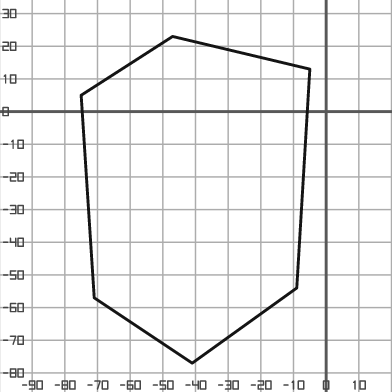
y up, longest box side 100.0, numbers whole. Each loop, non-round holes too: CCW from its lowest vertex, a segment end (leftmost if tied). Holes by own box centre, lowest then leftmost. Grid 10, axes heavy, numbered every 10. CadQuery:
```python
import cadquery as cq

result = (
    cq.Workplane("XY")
    .moveTo(-41.0, -77.0)
    .lineTo(-9.0, -54.0)
    .lineTo(-5.0, 13.0)
    .lineTo(-47.0, 23.0)
    .lineTo(-75.0, 5.0)
    .lineTo(-71.0, -57.0)
    .close()
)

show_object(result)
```